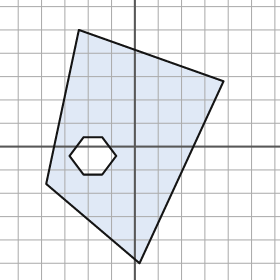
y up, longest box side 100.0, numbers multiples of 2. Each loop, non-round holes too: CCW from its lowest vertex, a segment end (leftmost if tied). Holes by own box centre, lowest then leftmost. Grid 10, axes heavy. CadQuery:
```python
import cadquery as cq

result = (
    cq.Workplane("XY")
    .moveTo(2.0, -50.0)
    .lineTo(38.0, 28.0)
    .lineTo(-24.0, 50.0)
    .lineTo(-38.0, -16.0)
    .close()
    .moveTo(-22.0, -12.0)
    .lineTo(-14.0, -12.0)
    .lineTo(-8.0, -4.0)
    .lineTo(-14.0, 4.0)
    .lineTo(-22.0, 4.0)
    .lineTo(-28.0, -4.0)
    .close()
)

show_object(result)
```